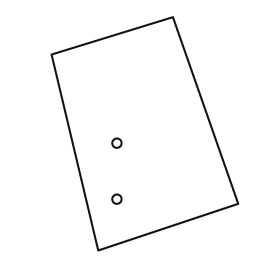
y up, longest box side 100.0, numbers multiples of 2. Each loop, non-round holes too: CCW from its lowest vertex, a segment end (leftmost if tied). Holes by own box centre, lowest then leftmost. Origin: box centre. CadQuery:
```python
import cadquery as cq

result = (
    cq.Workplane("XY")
    .moveTo(-20.0, -50.0)
    .lineTo(40.0, -30.0)
    .lineTo(12.0, 50.0)
    .lineTo(-40.0, 34.0)
    .close()
    .moveTo(-12.0, -28.0)
    .circle(2.0)
    .moveTo(-12.0, -4.0)
    .circle(2.0)
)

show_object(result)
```